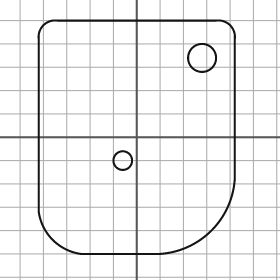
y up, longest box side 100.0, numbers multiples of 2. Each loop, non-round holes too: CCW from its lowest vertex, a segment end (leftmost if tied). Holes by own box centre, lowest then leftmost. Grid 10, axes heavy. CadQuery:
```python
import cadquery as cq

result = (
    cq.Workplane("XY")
    .moveTo(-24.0, -50.0)
    .lineTo(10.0, -50.0)
    .threePointArc((32.0, -40.0), (42.0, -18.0))
    .lineTo(42.0, 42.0)
    .threePointArc((40.0, 48.0), (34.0, 50.0))
    .lineTo(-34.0, 50.0)
    .threePointArc((-40.0, 48.0), (-42.0, 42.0))
    .lineTo(-42.0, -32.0)
    .threePointArc((-36.0, -44.0), (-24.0, -50.0))
    .close()
    .moveTo(-6.0, -10.0)
    .circle(4.0)
    .moveTo(28.0, 34.0)
    .circle(6.0)
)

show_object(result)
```